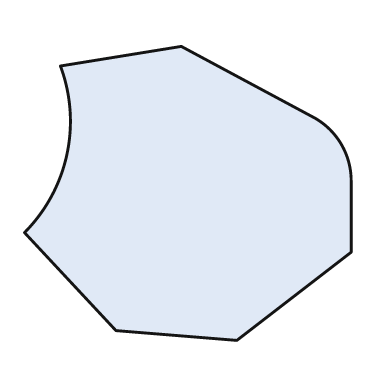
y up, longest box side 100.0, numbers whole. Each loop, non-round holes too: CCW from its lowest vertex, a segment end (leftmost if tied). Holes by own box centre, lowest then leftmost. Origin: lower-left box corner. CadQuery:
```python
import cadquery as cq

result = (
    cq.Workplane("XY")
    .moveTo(65.0, 0.0)
    .lineTo(100.0, 27.0)
    .lineTo(100.0, 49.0)
    .threePointArc((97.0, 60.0), (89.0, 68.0))
    .lineTo(48.0, 90.0)
    .lineTo(11.0, 84.0)
    .threePointArc((13.0, 57.0), (0.0, 33.0))
    .lineTo(28.0, 3.0)
    .close()
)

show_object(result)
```